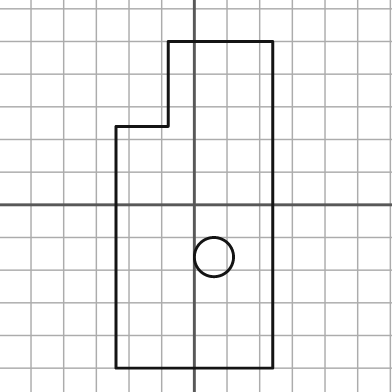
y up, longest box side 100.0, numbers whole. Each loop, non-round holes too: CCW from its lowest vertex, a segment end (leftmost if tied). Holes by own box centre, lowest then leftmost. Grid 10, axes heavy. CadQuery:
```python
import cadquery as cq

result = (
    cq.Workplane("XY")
    .moveTo(-24.0, -50.0)
    .lineTo(24.0, -50.0)
    .lineTo(24.0, 50.0)
    .lineTo(-8.0, 50.0)
    .lineTo(-8.0, 24.0)
    .lineTo(-24.0, 24.0)
    .close()
    .moveTo(6.0, -16.0)
    .circle(6.0)
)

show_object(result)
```